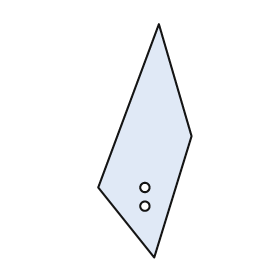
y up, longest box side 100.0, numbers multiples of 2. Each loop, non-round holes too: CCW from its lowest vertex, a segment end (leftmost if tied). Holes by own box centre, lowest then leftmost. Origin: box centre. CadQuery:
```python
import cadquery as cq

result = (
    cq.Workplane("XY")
    .moveTo(4.0, -50.0)
    .lineTo(20.0, 2.0)
    .lineTo(6.0, 50.0)
    .lineTo(-20.0, -20.0)
    .close()
    .moveTo(0.0, -28.0)
    .circle(2.0)
    .moveTo(0.0, -20.0)
    .circle(2.0)
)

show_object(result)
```